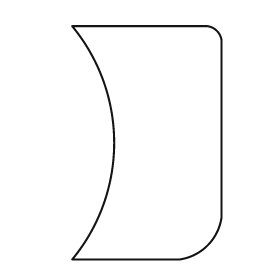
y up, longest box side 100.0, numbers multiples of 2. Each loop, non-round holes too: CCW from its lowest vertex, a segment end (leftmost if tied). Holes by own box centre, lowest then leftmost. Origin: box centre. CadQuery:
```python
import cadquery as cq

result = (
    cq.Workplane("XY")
    .moveTo(-32.0, -50.0)
    .lineTo(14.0, -50.0)
    .threePointArc((26.0, -44.0), (32.0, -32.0))
    .lineTo(32.0, 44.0)
    .threePointArc((30.0, 48.0), (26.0, 50.0))
    .lineTo(-32.0, 50.0)
    .threePointArc((-14.0, 0.0), (-32.0, -50.0))
    .close()
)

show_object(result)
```